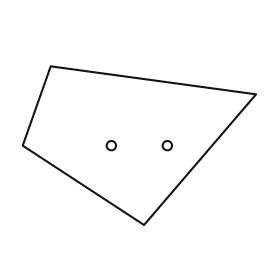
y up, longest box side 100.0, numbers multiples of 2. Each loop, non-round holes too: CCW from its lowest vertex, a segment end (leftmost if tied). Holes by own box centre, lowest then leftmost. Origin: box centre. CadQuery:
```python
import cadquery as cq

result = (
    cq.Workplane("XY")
    .moveTo(2.0, -34.0)
    .lineTo(50.0, 22.0)
    .lineTo(-38.0, 34.0)
    .lineTo(-50.0, 0.0)
    .close()
    .moveTo(-12.0, 0.0)
    .circle(2.0)
    .moveTo(12.0, 0.0)
    .circle(2.0)
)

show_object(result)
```